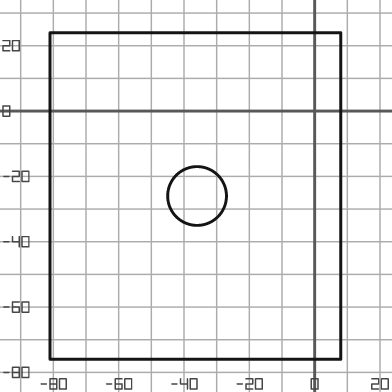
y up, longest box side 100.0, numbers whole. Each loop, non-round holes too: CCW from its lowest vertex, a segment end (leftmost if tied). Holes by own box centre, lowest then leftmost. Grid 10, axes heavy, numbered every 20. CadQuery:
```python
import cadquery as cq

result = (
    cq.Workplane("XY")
    .moveTo(-81.0, -76.0)
    .lineTo(8.0, -76.0)
    .lineTo(8.0, 24.0)
    .lineTo(-81.0, 24.0)
    .close()
    .moveTo(-36.0, -26.0)
    .circle(9.0)
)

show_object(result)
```